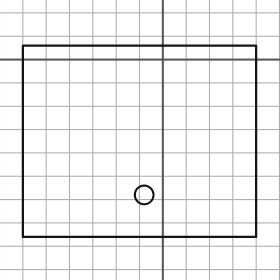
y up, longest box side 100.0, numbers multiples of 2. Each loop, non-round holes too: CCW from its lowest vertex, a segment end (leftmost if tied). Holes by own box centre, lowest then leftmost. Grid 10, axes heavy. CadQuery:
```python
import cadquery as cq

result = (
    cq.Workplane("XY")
    .moveTo(-60.0, -76.0)
    .lineTo(40.0, -76.0)
    .lineTo(40.0, 6.0)
    .lineTo(-60.0, 6.0)
    .close()
    .moveTo(-8.0, -58.0)
    .circle(4.0)
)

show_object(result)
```